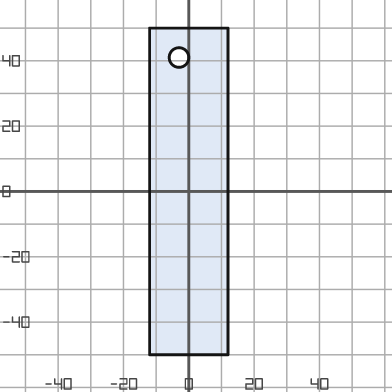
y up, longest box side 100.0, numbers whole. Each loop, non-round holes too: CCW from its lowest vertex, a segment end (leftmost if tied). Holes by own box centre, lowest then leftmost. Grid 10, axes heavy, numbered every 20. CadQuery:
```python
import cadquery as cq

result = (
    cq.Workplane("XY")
    .moveTo(-12.0, -50.0)
    .lineTo(12.0, -50.0)
    .lineTo(12.0, 50.0)
    .lineTo(-12.0, 50.0)
    .close()
    .moveTo(-3.0, 41.0)
    .circle(3.0)
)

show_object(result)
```